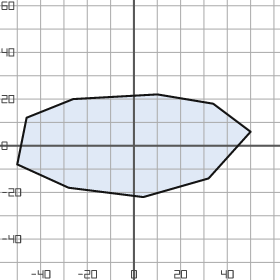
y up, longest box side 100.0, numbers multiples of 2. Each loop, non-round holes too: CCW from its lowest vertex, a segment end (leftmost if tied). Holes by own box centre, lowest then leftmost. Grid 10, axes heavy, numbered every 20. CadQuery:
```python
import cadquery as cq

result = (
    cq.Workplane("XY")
    .moveTo(4.0, -22.0)
    .lineTo(32.0, -14.0)
    .lineTo(50.0, 6.0)
    .lineTo(34.0, 18.0)
    .lineTo(10.0, 22.0)
    .lineTo(-26.0, 20.0)
    .lineTo(-46.0, 12.0)
    .lineTo(-50.0, -8.0)
    .lineTo(-28.0, -18.0)
    .close()
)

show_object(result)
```